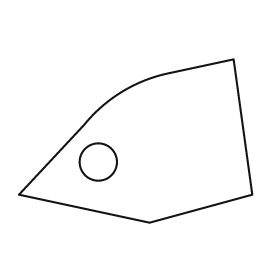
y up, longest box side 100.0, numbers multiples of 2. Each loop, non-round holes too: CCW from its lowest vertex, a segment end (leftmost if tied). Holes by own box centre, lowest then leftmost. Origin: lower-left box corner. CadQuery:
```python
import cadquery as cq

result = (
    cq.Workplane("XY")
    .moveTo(56.0, 0.0)
    .lineTo(100.0, 12.0)
    .lineTo(92.0, 70.0)
    .lineTo(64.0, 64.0)
    .threePointArc((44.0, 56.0), (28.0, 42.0))
    .lineTo(0.0, 12.0)
    .close()
    .moveTo(34.0, 26.0)
    .circle(8.0)
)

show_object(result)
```